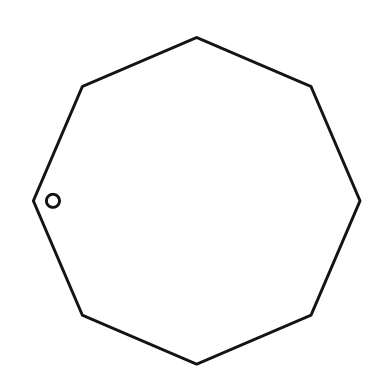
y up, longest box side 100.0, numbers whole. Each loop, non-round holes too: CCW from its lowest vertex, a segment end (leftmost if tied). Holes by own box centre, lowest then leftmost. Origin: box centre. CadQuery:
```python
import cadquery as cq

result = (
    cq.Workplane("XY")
    .moveTo(0.0, -50.0)
    .lineTo(35.0, -35.0)
    .lineTo(50.0, 0.0)
    .lineTo(35.0, 35.0)
    .lineTo(0.0, 50.0)
    .lineTo(-35.0, 35.0)
    .lineTo(-50.0, 0.0)
    .lineTo(-35.0, -35.0)
    .close()
    .moveTo(-44.0, 0.0)
    .circle(2.0)
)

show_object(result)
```